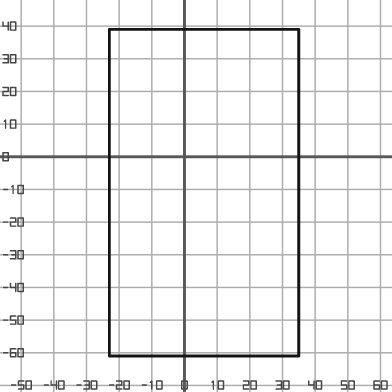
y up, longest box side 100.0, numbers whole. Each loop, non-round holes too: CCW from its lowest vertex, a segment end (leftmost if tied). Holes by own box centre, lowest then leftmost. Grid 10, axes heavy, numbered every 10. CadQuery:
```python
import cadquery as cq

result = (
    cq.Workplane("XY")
    .moveTo(-23.0, -61.0)
    .lineTo(35.0, -61.0)
    .lineTo(35.0, 39.0)
    .lineTo(-23.0, 39.0)
    .close()
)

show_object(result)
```